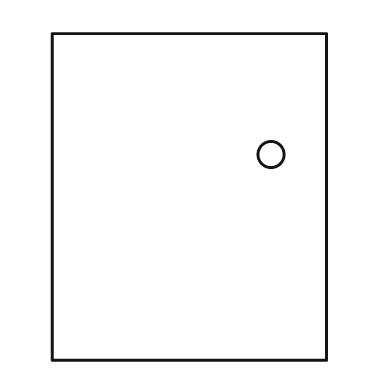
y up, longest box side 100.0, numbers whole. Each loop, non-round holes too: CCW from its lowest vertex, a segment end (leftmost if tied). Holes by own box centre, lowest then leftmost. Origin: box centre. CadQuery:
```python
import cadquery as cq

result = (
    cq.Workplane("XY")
    .moveTo(-42.0, -50.0)
    .lineTo(42.0, -50.0)
    .lineTo(42.0, 50.0)
    .lineTo(-42.0, 50.0)
    .close()
    .moveTo(25.0, 13.0)
    .circle(4.0)
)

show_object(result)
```